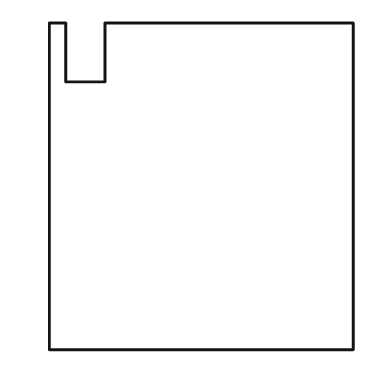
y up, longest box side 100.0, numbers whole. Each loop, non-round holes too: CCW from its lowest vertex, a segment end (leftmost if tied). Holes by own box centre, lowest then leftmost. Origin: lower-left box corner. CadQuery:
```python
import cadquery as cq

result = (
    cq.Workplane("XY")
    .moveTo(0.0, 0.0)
    .lineTo(93.0, 0.0)
    .lineTo(93.0, 100.0)
    .lineTo(17.0, 100.0)
    .lineTo(17.0, 82.0)
    .lineTo(5.0, 82.0)
    .lineTo(5.0, 100.0)
    .lineTo(0.0, 100.0)
    .close()
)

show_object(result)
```